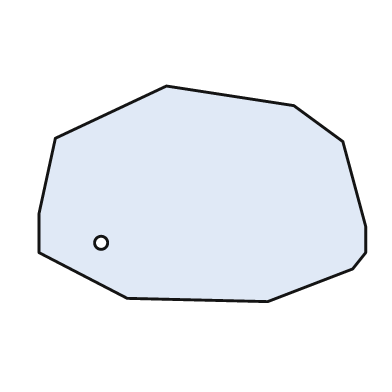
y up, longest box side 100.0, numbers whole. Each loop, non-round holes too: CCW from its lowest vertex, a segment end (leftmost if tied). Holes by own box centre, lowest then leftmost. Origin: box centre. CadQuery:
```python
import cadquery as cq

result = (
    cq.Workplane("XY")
    .moveTo(20.0, -33.0)
    .lineTo(46.0, -23.0)
    .lineTo(50.0, -18.0)
    .lineTo(50.0, -10.0)
    .lineTo(43.0, 16.0)
    .lineTo(28.0, 27.0)
    .lineTo(-11.0, 33.0)
    .lineTo(-45.0, 17.0)
    .lineTo(-50.0, -6.0)
    .lineTo(-50.0, -18.0)
    .lineTo(-23.0, -32.0)
    .close()
    .moveTo(-31.0, -15.0)
    .circle(2.0)
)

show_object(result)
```